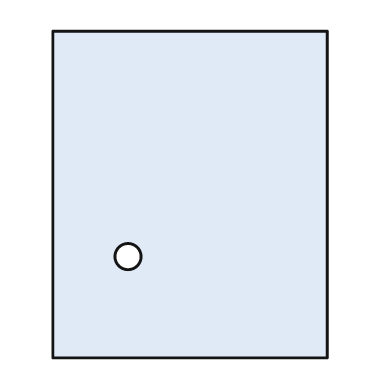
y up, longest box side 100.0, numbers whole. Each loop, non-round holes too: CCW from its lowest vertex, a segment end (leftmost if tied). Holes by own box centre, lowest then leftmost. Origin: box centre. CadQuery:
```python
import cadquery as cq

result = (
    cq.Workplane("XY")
    .moveTo(-42.0, -50.0)
    .lineTo(42.0, -50.0)
    .lineTo(42.0, 50.0)
    .lineTo(-42.0, 50.0)
    .close()
    .moveTo(-19.0, -19.0)
    .circle(4.0)
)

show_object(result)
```